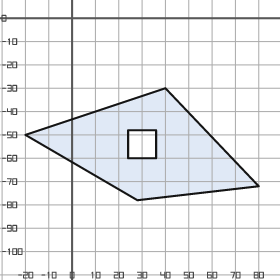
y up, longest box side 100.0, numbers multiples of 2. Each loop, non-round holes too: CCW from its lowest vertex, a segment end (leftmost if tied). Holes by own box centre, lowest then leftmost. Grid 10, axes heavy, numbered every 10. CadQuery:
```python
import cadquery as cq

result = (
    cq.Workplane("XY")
    .moveTo(28.0, -78.0)
    .lineTo(80.0, -72.0)
    .lineTo(40.0, -30.0)
    .lineTo(-20.0, -50.0)
    .close()
    .moveTo(24.0, -60.0)
    .lineTo(36.0, -60.0)
    .lineTo(36.0, -48.0)
    .lineTo(24.0, -48.0)
    .close()
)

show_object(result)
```